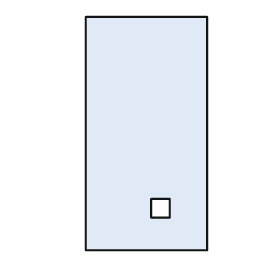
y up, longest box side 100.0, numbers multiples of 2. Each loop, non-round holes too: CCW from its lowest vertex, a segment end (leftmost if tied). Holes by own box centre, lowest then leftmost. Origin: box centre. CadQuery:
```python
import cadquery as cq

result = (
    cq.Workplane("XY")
    .moveTo(-26.0, -50.0)
    .lineTo(26.0, -50.0)
    .lineTo(26.0, 50.0)
    .lineTo(-26.0, 50.0)
    .close()
    .moveTo(2.0, -36.0)
    .lineTo(10.0, -36.0)
    .lineTo(10.0, -28.0)
    .lineTo(2.0, -28.0)
    .close()
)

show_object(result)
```